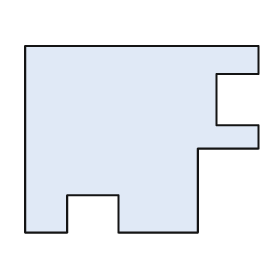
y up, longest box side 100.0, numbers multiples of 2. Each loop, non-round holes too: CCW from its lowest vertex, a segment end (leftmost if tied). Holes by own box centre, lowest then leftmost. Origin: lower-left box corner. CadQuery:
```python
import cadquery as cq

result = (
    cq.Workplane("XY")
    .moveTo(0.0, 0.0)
    .lineTo(18.0, 0.0)
    .lineTo(18.0, 16.0)
    .lineTo(40.0, 16.0)
    .lineTo(40.0, 0.0)
    .lineTo(74.0, 0.0)
    .lineTo(74.0, 36.0)
    .lineTo(100.0, 36.0)
    .lineTo(100.0, 46.0)
    .lineTo(82.0, 46.0)
    .lineTo(82.0, 68.0)
    .lineTo(100.0, 68.0)
    .lineTo(100.0, 80.0)
    .lineTo(0.0, 80.0)
    .close()
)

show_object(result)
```